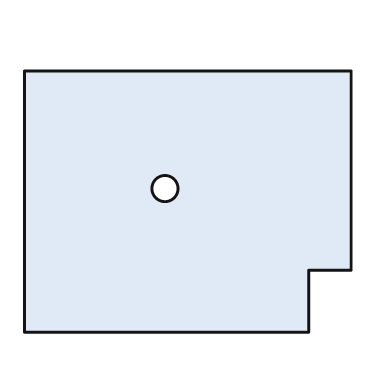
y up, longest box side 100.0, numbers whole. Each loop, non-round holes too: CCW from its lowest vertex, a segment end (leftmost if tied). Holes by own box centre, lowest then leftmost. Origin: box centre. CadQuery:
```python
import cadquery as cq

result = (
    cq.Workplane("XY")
    .moveTo(-50.0, -40.0)
    .lineTo(37.0, -40.0)
    .lineTo(37.0, -21.0)
    .lineTo(50.0, -21.0)
    .lineTo(50.0, 40.0)
    .lineTo(-50.0, 40.0)
    .close()
    .moveTo(-7.0, 4.0)
    .circle(4.0)
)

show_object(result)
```